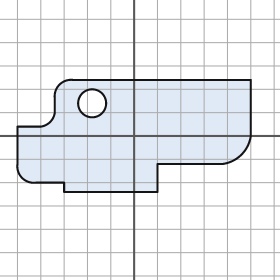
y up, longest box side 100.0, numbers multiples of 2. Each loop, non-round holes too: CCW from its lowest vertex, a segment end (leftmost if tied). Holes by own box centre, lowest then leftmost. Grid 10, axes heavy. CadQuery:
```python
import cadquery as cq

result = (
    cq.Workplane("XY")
    .moveTo(-30.0, -24.0)
    .lineTo(10.0, -24.0)
    .lineTo(10.0, -12.0)
    .lineTo(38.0, -12.0)
    .threePointArc((46.0, -8.0), (50.0, 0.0))
    .lineTo(50.0, 24.0)
    .lineTo(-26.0, 24.0)
    .threePointArc((-32.0, 22.0), (-34.0, 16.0))
    .lineTo(-34.0, 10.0)
    .threePointArc((-36.0, 6.0), (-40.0, 4.0))
    .lineTo(-50.0, 4.0)
    .lineTo(-50.0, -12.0)
    .threePointArc((-48.0, -18.0), (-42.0, -20.0))
    .lineTo(-30.0, -20.0)
    .close()
    .moveTo(-18.0, 14.0)
    .circle(6.0)
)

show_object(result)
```